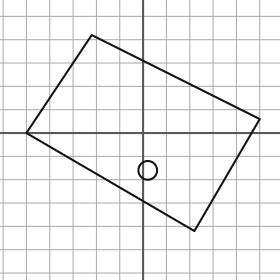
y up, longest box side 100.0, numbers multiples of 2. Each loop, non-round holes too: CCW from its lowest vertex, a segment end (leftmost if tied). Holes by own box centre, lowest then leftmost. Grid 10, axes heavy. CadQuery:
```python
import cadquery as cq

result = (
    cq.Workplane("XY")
    .moveTo(22.0, -42.0)
    .lineTo(50.0, 6.0)
    .lineTo(-22.0, 42.0)
    .lineTo(-50.0, 0.0)
    .close()
    .moveTo(2.0, -16.0)
    .circle(4.0)
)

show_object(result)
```